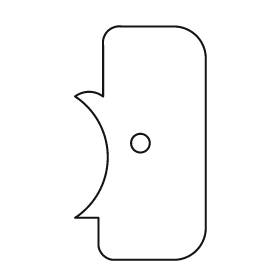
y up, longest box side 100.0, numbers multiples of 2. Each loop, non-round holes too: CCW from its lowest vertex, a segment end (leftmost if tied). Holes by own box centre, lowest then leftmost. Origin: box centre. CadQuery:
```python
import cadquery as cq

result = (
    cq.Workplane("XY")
    .moveTo(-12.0, -50.0)
    .lineTo(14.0, -50.0)
    .threePointArc((24.0, -46.0), (28.0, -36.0))
    .lineTo(28.0, 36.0)
    .threePointArc((24.0, 46.0), (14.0, 50.0))
    .lineTo(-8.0, 50.0)
    .threePointArc((-14.0, 48.0), (-16.0, 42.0))
    .lineTo(-16.0, 20.0)
    .threePointArc((-22.0, 22.0), (-28.0, 20.0))
    .threePointArc((-14.0, -6.0), (-28.0, -32.0))
    .lineTo(-18.0, -32.0)
    .lineTo(-18.0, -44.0)
    .threePointArc((-16.0, -48.0), (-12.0, -50.0))
    .close()
    .moveTo(0.0, 0.0)
    .circle(4.0)
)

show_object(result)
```